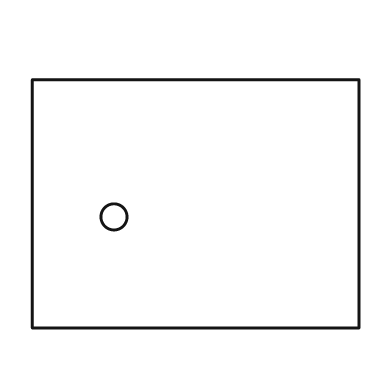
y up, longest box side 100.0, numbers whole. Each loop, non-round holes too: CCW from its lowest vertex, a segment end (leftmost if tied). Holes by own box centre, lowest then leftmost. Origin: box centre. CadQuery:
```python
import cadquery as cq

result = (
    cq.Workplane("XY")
    .moveTo(-50.0, -38.0)
    .lineTo(50.0, -38.0)
    .lineTo(50.0, 38.0)
    .lineTo(-50.0, 38.0)
    .close()
    .moveTo(-25.0, -4.0)
    .circle(4.0)
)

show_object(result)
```